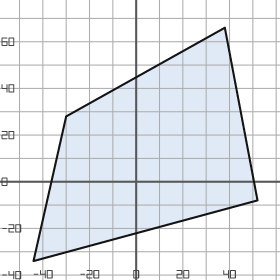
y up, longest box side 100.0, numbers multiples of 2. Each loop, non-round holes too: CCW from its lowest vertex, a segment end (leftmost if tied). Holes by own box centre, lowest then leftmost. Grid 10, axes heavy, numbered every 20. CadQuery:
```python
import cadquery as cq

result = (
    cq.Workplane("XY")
    .moveTo(-44.0, -34.0)
    .lineTo(52.0, -8.0)
    .lineTo(38.0, 66.0)
    .lineTo(-30.0, 28.0)
    .close()
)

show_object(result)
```